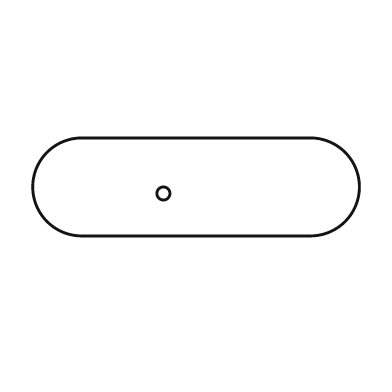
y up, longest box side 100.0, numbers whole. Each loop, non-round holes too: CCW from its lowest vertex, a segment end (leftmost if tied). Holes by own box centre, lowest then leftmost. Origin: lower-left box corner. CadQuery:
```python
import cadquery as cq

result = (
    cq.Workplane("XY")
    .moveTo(15.0, 0.0)
    .lineTo(85.0, 0.0)
    .threePointArc((100.0, 15.0), (85.0, 30.0))
    .lineTo(15.0, 30.0)
    .threePointArc((0.0, 15.0), (15.0, 0.0))
    .close()
    .moveTo(40.0, 13.0)
    .circle(2.0)
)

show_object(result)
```